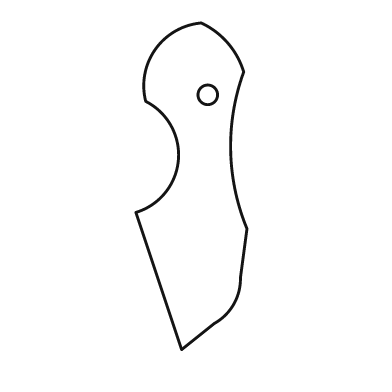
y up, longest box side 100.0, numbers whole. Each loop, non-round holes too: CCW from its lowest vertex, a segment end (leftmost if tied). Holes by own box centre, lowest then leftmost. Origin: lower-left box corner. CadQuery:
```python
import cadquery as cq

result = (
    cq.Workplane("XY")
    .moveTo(14.0, 0.0)
    .lineTo(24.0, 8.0)
    .threePointArc((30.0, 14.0), (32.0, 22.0))
    .lineTo(34.0, 37.0)
    .threePointArc((29.0, 61.0), (33.0, 85.0))
    .threePointArc((28.0, 94.0), (20.0, 100.0))
    .threePointArc((6.0, 92.0), (3.0, 76.0))
    .threePointArc((13.0, 58.0), (0.0, 42.0))
    .close()
    .moveTo(22.0, 78.0)
    .circle(3.0)
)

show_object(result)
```